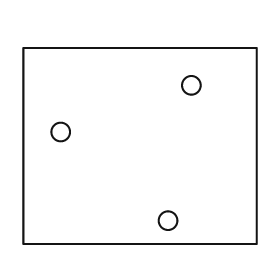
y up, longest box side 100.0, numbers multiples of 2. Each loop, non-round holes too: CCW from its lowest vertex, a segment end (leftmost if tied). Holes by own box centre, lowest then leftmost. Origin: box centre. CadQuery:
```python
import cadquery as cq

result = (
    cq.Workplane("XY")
    .moveTo(-50.0, -42.0)
    .lineTo(50.0, -42.0)
    .lineTo(50.0, 42.0)
    .lineTo(-50.0, 42.0)
    .close()
    .moveTo(12.0, -32.0)
    .circle(4.0)
    .moveTo(-34.0, 6.0)
    .circle(4.0)
    .moveTo(22.0, 26.0)
    .circle(4.0)
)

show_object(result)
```